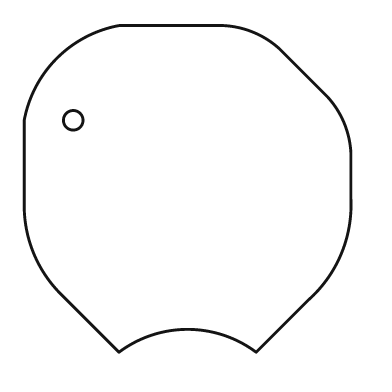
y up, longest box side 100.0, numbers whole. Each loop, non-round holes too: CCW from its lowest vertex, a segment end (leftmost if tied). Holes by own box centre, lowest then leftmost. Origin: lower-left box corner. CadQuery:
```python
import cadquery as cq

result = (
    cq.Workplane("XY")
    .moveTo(29.0, 0.0)
    .threePointArc((50.0, 7.0), (71.0, 0.0))
    .lineTo(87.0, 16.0)
    .threePointArc((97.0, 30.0), (100.0, 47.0))
    .lineTo(100.0, 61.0)
    .threePointArc((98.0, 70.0), (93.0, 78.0))
    .lineTo(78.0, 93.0)
    .threePointArc((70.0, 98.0), (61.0, 100.0))
    .lineTo(29.0, 100.0)
    .threePointArc((10.0, 90.0), (0.0, 71.0))
    .lineTo(0.0, 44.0)
    .threePointArc((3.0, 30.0), (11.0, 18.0))
    .close()
    .moveTo(15.0, 71.0)
    .circle(3.0)
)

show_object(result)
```